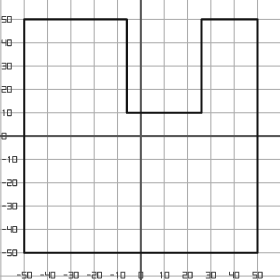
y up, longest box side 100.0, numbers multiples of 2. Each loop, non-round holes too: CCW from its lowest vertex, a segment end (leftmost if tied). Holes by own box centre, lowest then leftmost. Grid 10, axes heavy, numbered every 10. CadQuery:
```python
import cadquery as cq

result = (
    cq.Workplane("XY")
    .moveTo(-50.0, -50.0)
    .lineTo(50.0, -50.0)
    .lineTo(50.0, 50.0)
    .lineTo(26.0, 50.0)
    .lineTo(26.0, 10.0)
    .lineTo(-6.0, 10.0)
    .lineTo(-6.0, 50.0)
    .lineTo(-50.0, 50.0)
    .close()
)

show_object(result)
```